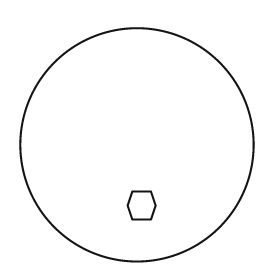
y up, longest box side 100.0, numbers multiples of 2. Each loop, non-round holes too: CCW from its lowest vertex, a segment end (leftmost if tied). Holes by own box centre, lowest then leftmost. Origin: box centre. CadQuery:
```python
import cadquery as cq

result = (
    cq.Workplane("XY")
    .moveTo(0.0, 0.0)
    .circle(50.0)
    .moveTo(-2.0, -32.0)
    .lineTo(6.0, -32.0)
    .lineTo(8.0, -26.0)
    .lineTo(6.0, -20.0)
    .lineTo(-2.0, -20.0)
    .lineTo(-4.0, -26.0)
    .close()
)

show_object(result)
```